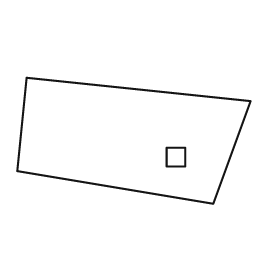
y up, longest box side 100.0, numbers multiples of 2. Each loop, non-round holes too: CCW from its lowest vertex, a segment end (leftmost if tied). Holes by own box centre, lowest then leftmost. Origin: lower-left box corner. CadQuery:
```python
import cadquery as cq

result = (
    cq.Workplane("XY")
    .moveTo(84.0, 0.0)
    .lineTo(100.0, 44.0)
    .lineTo(4.0, 54.0)
    .lineTo(0.0, 14.0)
    .close()
    .moveTo(64.0, 16.0)
    .lineTo(72.0, 16.0)
    .lineTo(72.0, 24.0)
    .lineTo(64.0, 24.0)
    .close()
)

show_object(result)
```